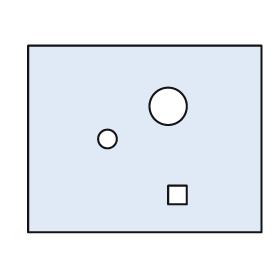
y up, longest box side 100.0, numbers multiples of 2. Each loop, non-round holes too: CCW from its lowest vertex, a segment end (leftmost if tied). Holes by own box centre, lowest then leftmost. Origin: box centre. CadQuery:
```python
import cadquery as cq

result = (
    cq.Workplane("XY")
    .moveTo(-50.0, -40.0)
    .lineTo(50.0, -40.0)
    .lineTo(50.0, 40.0)
    .lineTo(-50.0, 40.0)
    .close()
    .moveTo(10.0, -28.0)
    .lineTo(18.0, -28.0)
    .lineTo(18.0, -20.0)
    .lineTo(10.0, -20.0)
    .close()
    .moveTo(-16.0, 0.0)
    .circle(4.0)
    .moveTo(10.0, 14.0)
    .circle(8.0)
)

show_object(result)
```